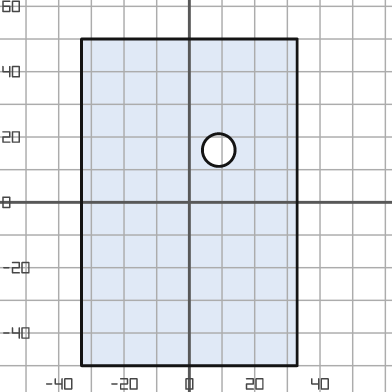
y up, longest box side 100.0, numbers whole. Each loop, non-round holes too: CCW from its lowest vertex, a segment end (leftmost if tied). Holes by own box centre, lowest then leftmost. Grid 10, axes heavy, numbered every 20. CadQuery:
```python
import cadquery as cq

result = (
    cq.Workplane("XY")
    .moveTo(-33.0, -50.0)
    .lineTo(33.0, -50.0)
    .lineTo(33.0, 50.0)
    .lineTo(-33.0, 50.0)
    .close()
    .moveTo(9.0, 16.0)
    .circle(5.0)
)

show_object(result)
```